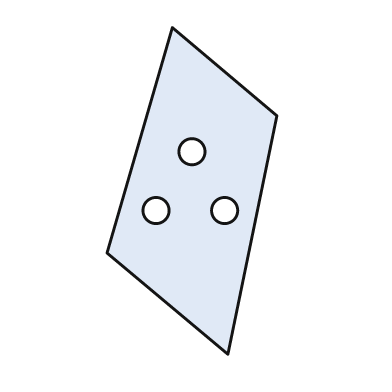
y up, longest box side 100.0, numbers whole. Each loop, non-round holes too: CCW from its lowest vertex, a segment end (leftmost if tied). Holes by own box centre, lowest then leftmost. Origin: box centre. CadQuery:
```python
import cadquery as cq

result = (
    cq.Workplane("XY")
    .moveTo(11.0, -50.0)
    .lineTo(26.0, 23.0)
    .lineTo(-6.0, 50.0)
    .lineTo(-26.0, -19.0)
    .close()
    .moveTo(-11.0, -6.0)
    .circle(4.0)
    .moveTo(10.0, -6.0)
    .circle(4.0)
    .moveTo(0.0, 12.0)
    .circle(4.0)
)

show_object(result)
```